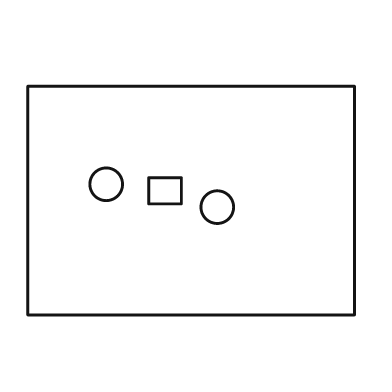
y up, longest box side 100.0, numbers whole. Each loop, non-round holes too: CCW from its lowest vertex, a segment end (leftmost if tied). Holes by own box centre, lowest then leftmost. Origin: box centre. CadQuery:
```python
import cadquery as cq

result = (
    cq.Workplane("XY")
    .moveTo(-50.0, -35.0)
    .lineTo(50.0, -35.0)
    .lineTo(50.0, 35.0)
    .lineTo(-50.0, 35.0)
    .close()
    .moveTo(8.0, -2.0)
    .circle(5.0)
    .moveTo(-13.0, -1.0)
    .lineTo(-3.0, -1.0)
    .lineTo(-3.0, 7.0)
    .lineTo(-13.0, 7.0)
    .close()
    .moveTo(-26.0, 5.0)
    .circle(5.0)
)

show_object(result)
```